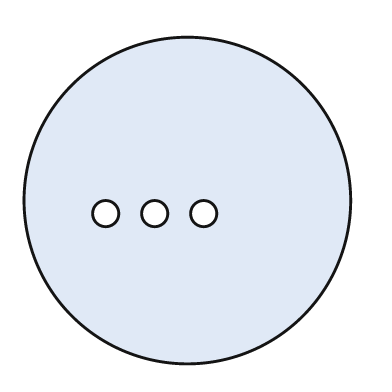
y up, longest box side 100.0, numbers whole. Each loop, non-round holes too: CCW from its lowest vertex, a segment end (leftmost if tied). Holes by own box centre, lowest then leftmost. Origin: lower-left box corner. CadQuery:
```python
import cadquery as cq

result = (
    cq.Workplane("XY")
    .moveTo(50.0, 50.0)
    .circle(50.0)
    .moveTo(25.0, 46.0)
    .circle(4.0)
    .moveTo(40.0, 46.0)
    .circle(4.0)
    .moveTo(55.0, 46.0)
    .circle(4.0)
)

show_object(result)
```